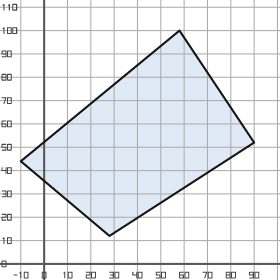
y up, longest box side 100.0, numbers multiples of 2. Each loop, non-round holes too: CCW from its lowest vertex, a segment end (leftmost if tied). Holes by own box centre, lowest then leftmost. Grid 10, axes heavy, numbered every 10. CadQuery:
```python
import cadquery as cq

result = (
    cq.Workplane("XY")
    .moveTo(28.0, 12.0)
    .lineTo(90.0, 52.0)
    .lineTo(58.0, 100.0)
    .lineTo(-10.0, 44.0)
    .close()
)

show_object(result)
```